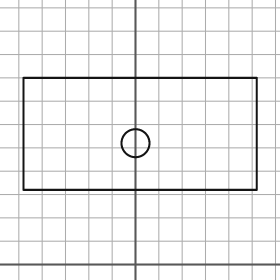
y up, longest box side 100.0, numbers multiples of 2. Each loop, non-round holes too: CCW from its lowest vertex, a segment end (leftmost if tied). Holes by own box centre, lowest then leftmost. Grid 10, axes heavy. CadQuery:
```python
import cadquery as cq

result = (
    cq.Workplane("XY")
    .moveTo(-48.0, 32.0)
    .lineTo(52.0, 32.0)
    .lineTo(52.0, 80.0)
    .lineTo(-48.0, 80.0)
    .close()
    .moveTo(0.0, 52.0)
    .circle(6.0)
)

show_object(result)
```